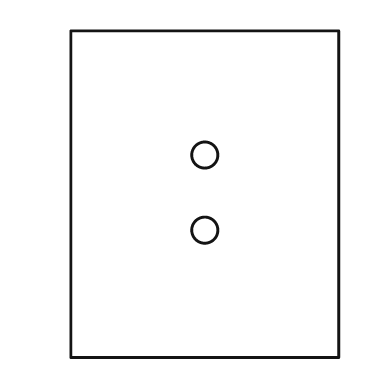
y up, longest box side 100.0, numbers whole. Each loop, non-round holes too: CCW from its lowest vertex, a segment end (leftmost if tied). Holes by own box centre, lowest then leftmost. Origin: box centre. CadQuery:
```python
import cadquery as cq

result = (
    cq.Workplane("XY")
    .moveTo(-41.0, -50.0)
    .lineTo(41.0, -50.0)
    .lineTo(41.0, 50.0)
    .lineTo(-41.0, 50.0)
    .close()
    .moveTo(0.0, -11.0)
    .circle(4.0)
    .moveTo(0.0, 12.0)
    .circle(4.0)
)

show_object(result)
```